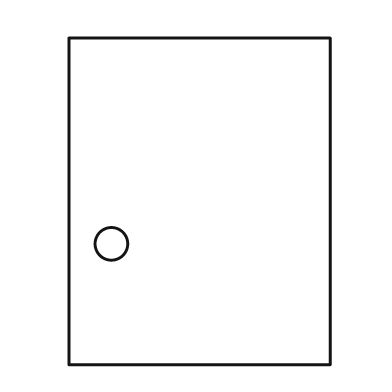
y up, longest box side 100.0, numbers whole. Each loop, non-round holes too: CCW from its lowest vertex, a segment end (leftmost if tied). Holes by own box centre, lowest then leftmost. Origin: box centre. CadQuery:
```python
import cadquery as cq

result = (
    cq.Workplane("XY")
    .moveTo(-40.0, -50.0)
    .lineTo(40.0, -50.0)
    .lineTo(40.0, 50.0)
    .lineTo(-40.0, 50.0)
    .close()
    .moveTo(-27.0, -13.0)
    .circle(5.0)
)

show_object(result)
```